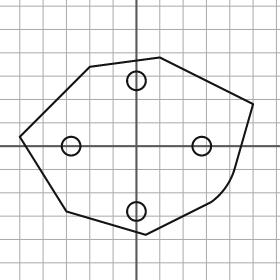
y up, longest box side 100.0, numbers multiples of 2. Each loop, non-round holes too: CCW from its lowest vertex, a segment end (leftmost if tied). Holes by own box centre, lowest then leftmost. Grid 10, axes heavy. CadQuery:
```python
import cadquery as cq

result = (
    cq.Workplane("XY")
    .moveTo(4.0, -38.0)
    .lineTo(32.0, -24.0)
    .threePointArc((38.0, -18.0), (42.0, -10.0))
    .lineTo(50.0, 18.0)
    .lineTo(10.0, 38.0)
    .lineTo(-20.0, 34.0)
    .lineTo(-50.0, 4.0)
    .lineTo(-30.0, -28.0)
    .close()
    .moveTo(0.0, -28.0)
    .circle(4.0)
    .moveTo(-28.0, 0.0)
    .circle(4.0)
    .moveTo(28.0, 0.0)
    .circle(4.0)
    .moveTo(0.0, 28.0)
    .circle(4.0)
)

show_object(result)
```